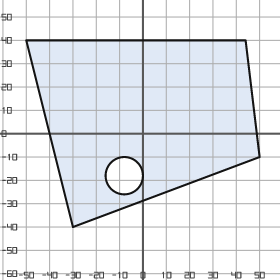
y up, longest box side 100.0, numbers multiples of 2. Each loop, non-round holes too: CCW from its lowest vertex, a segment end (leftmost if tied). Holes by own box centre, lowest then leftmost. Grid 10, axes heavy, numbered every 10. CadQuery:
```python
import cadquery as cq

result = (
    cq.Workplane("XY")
    .moveTo(-30.0, -40.0)
    .lineTo(50.0, -10.0)
    .lineTo(44.0, 40.0)
    .lineTo(-50.0, 40.0)
    .close()
    .moveTo(-8.0, -18.0)
    .circle(8.0)
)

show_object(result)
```